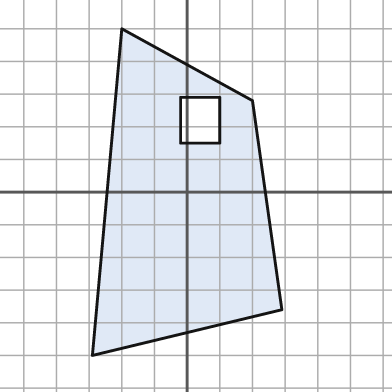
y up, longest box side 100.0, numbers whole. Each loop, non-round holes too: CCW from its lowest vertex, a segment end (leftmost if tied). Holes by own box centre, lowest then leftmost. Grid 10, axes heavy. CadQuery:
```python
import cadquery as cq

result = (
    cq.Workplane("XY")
    .moveTo(-29.0, -50.0)
    .lineTo(29.0, -36.0)
    .lineTo(20.0, 28.0)
    .lineTo(-20.0, 50.0)
    .close()
    .moveTo(-2.0, 15.0)
    .lineTo(10.0, 15.0)
    .lineTo(10.0, 29.0)
    .lineTo(-2.0, 29.0)
    .close()
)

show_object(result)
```